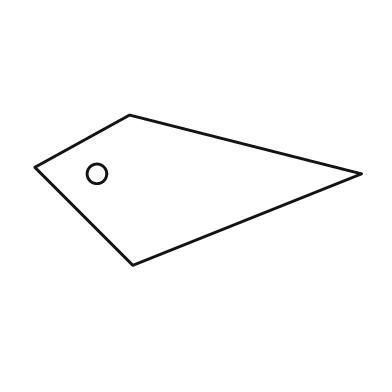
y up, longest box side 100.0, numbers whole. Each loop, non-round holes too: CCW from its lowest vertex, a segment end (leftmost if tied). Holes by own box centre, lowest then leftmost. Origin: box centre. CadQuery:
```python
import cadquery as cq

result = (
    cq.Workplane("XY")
    .moveTo(-20.0, -23.0)
    .lineTo(50.0, 5.0)
    .lineTo(-21.0, 23.0)
    .lineTo(-50.0, 7.0)
    .close()
    .moveTo(-31.0, 5.0)
    .circle(3.0)
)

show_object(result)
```